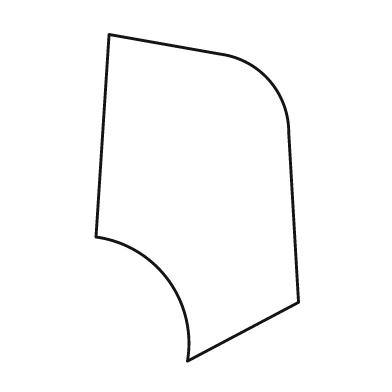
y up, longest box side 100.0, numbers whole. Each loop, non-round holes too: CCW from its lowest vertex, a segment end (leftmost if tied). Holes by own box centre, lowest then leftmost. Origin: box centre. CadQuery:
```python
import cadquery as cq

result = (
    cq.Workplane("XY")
    .moveTo(-3.0, -50.0)
    .lineTo(31.0, -32.0)
    .lineTo(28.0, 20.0)
    .threePointArc((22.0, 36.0), (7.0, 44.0))
    .lineTo(-27.0, 50.0)
    .lineTo(-31.0, -12.0)
    .threePointArc((-9.0, -25.0), (-3.0, -50.0))
    .close()
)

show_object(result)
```